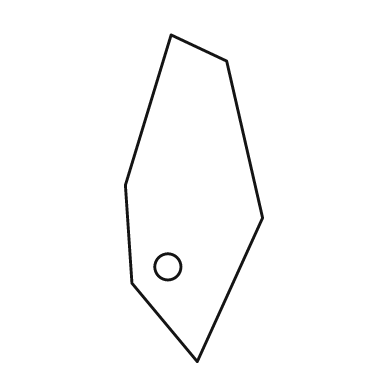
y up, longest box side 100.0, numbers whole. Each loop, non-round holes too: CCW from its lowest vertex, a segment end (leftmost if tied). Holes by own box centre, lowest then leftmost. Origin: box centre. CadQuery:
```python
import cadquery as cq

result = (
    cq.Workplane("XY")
    .moveTo(1.0, -50.0)
    .lineTo(21.0, -6.0)
    .lineTo(10.0, 42.0)
    .lineTo(-7.0, 50.0)
    .lineTo(-21.0, 4.0)
    .lineTo(-19.0, -26.0)
    .close()
    .moveTo(-8.0, -21.0)
    .circle(4.0)
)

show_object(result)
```